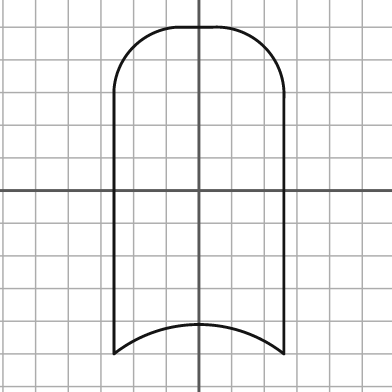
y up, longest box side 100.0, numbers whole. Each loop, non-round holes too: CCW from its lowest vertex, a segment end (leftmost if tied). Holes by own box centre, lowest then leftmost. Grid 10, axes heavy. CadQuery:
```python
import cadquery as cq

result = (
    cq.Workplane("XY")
    .moveTo(-26.0, -50.0)
    .threePointArc((0.0, -41.0), (26.0, -50.0))
    .lineTo(26.0, 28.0)
    .threePointArc((20.0, 44.0), (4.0, 50.0))
    .lineTo(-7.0, 50.0)
    .threePointArc((-20.0, 44.0), (-26.0, 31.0))
    .close()
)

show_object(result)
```